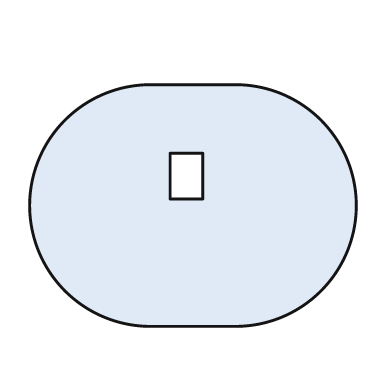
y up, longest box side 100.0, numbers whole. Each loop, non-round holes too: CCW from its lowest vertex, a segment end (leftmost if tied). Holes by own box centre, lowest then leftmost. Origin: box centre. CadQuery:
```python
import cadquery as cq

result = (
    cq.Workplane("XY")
    .moveTo(-13.0, -37.0)
    .lineTo(13.0, -37.0)
    .threePointArc((50.0, 0.0), (13.0, 37.0))
    .lineTo(-13.0, 37.0)
    .threePointArc((-50.0, 0.0), (-13.0, -37.0))
    .close()
    .moveTo(-7.0, 2.0)
    .lineTo(3.0, 2.0)
    .lineTo(3.0, 16.0)
    .lineTo(-7.0, 16.0)
    .close()
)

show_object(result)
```